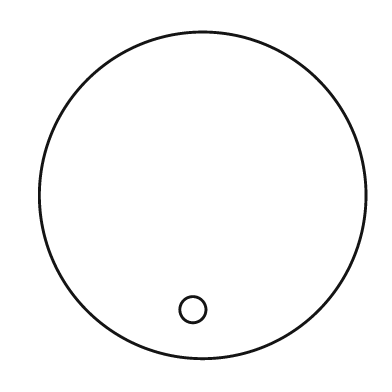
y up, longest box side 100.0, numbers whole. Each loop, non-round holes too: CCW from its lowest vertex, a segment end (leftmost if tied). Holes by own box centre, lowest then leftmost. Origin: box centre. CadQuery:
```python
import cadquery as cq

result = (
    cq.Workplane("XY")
    .moveTo(0.0, 0.0)
    .circle(50.0)
    .moveTo(-3.0, -35.0)
    .circle(4.0)
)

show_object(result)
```